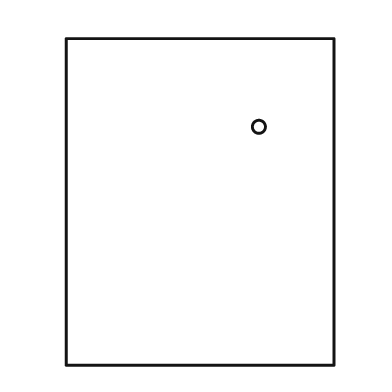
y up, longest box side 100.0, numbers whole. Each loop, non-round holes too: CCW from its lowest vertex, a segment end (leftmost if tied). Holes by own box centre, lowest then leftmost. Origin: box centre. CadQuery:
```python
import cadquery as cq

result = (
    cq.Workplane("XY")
    .moveTo(-41.0, -50.0)
    .lineTo(41.0, -50.0)
    .lineTo(41.0, 50.0)
    .lineTo(-41.0, 50.0)
    .close()
    .moveTo(18.0, 23.0)
    .circle(2.0)
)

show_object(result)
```